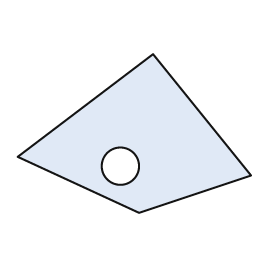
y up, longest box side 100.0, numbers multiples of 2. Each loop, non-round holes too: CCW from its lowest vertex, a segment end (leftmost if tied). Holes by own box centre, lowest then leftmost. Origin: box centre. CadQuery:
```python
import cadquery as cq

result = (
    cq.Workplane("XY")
    .moveTo(2.0, -34.0)
    .lineTo(50.0, -18.0)
    .lineTo(8.0, 34.0)
    .lineTo(-50.0, -10.0)
    .close()
    .moveTo(-6.0, -14.0)
    .circle(8.0)
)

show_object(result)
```